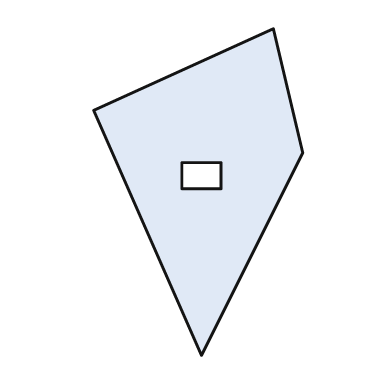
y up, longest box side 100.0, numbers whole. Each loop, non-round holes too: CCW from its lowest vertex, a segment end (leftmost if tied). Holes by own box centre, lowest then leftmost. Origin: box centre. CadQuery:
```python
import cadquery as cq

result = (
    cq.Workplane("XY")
    .moveTo(1.0, -50.0)
    .lineTo(32.0, 12.0)
    .lineTo(23.0, 50.0)
    .lineTo(-32.0, 25.0)
    .close()
    .moveTo(-5.0, 1.0)
    .lineTo(7.0, 1.0)
    .lineTo(7.0, 9.0)
    .lineTo(-5.0, 9.0)
    .close()
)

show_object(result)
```